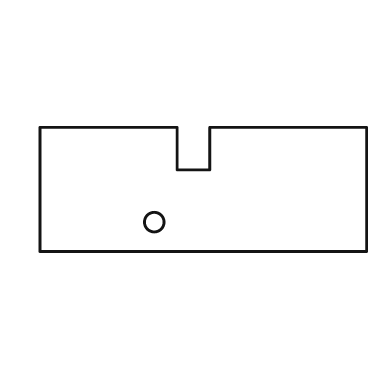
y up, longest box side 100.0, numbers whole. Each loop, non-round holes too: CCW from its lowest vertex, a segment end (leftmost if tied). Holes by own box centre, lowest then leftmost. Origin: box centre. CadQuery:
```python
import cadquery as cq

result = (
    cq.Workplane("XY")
    .moveTo(-50.0, -19.0)
    .lineTo(50.0, -19.0)
    .lineTo(50.0, 19.0)
    .lineTo(2.0, 19.0)
    .lineTo(2.0, 6.0)
    .lineTo(-8.0, 6.0)
    .lineTo(-8.0, 19.0)
    .lineTo(-50.0, 19.0)
    .close()
    .moveTo(-15.0, -10.0)
    .circle(3.0)
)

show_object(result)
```